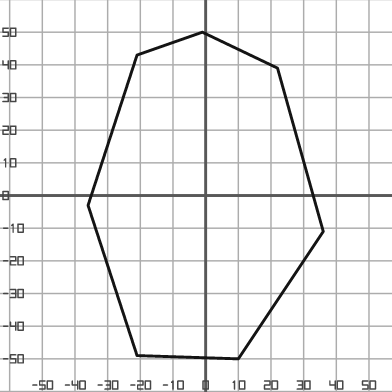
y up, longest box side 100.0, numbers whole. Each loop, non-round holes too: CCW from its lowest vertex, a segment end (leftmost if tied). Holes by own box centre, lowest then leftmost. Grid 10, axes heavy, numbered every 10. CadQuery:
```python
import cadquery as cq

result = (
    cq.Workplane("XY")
    .moveTo(10.0, -50.0)
    .lineTo(36.0, -11.0)
    .lineTo(22.0, 39.0)
    .lineTo(-1.0, 50.0)
    .lineTo(-21.0, 43.0)
    .lineTo(-36.0, -3.0)
    .lineTo(-21.0, -49.0)
    .close()
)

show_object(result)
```